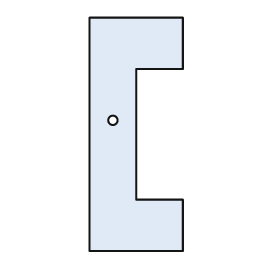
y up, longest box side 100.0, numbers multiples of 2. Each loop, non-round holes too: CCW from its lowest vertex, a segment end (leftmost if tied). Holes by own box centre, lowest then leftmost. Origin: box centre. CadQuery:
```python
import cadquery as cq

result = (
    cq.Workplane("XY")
    .moveTo(-20.0, -50.0)
    .lineTo(20.0, -50.0)
    .lineTo(20.0, -28.0)
    .lineTo(0.0, -28.0)
    .lineTo(0.0, 28.0)
    .lineTo(20.0, 28.0)
    .lineTo(20.0, 50.0)
    .lineTo(-20.0, 50.0)
    .close()
    .moveTo(-10.0, 6.0)
    .circle(2.0)
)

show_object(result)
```